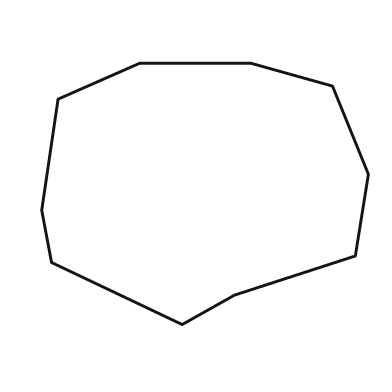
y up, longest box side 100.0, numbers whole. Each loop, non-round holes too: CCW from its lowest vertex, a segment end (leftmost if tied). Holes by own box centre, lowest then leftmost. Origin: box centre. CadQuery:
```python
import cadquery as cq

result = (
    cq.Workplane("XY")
    .moveTo(-7.0, -40.0)
    .lineTo(9.0, -31.0)
    .lineTo(46.0, -19.0)
    .lineTo(50.0, 6.0)
    .lineTo(39.0, 33.0)
    .lineTo(14.0, 40.0)
    .lineTo(-20.0, 40.0)
    .lineTo(-45.0, 29.0)
    .lineTo(-50.0, -5.0)
    .lineTo(-47.0, -21.0)
    .close()
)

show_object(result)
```